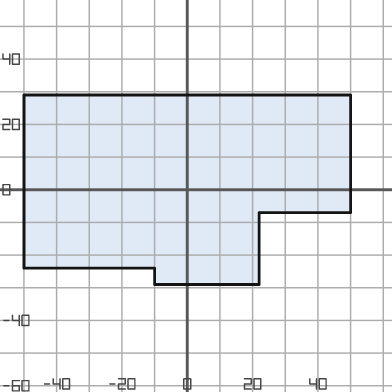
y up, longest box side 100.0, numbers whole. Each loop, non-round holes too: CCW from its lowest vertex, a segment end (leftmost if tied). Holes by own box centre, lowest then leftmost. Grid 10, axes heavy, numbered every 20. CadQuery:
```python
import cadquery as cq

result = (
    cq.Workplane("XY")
    .moveTo(-10.0, -29.0)
    .lineTo(22.0, -29.0)
    .lineTo(22.0, -7.0)
    .lineTo(50.0, -7.0)
    .lineTo(50.0, 29.0)
    .lineTo(-50.0, 29.0)
    .lineTo(-50.0, -24.0)
    .lineTo(-10.0, -24.0)
    .close()
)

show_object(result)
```